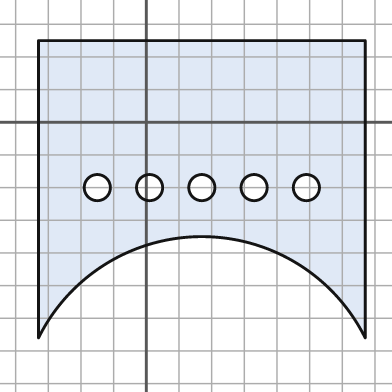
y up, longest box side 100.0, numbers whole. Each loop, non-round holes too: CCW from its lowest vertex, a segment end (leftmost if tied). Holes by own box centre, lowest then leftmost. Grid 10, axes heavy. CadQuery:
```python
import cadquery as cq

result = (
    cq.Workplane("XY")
    .moveTo(-33.0, -66.0)
    .threePointArc((17.0, -35.0), (67.0, -66.0))
    .lineTo(67.0, 25.0)
    .lineTo(-33.0, 25.0)
    .close()
    .moveTo(-15.0, -20.0)
    .circle(4.0)
    .moveTo(1.0, -20.0)
    .circle(4.0)
    .moveTo(17.0, -20.0)
    .circle(4.0)
    .moveTo(33.0, -20.0)
    .circle(4.0)
    .moveTo(49.0, -20.0)
    .circle(4.0)
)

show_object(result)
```